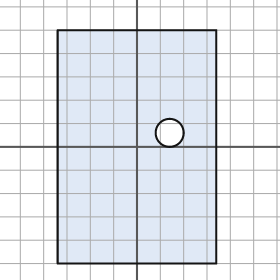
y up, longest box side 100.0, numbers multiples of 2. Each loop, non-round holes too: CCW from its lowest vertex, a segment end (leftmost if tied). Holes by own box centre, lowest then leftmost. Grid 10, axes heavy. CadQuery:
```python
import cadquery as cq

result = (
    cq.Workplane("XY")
    .moveTo(-34.0, -50.0)
    .lineTo(34.0, -50.0)
    .lineTo(34.0, 50.0)
    .lineTo(-34.0, 50.0)
    .close()
    .moveTo(14.0, 6.0)
    .circle(6.0)
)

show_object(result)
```